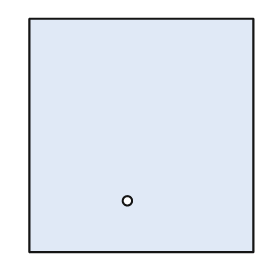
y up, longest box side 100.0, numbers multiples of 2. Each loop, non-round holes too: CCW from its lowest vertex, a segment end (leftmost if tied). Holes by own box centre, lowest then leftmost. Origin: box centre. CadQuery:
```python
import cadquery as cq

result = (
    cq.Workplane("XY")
    .moveTo(-48.0, -50.0)
    .lineTo(48.0, -50.0)
    .lineTo(48.0, 50.0)
    .lineTo(-48.0, 50.0)
    .close()
    .moveTo(-6.0, -28.0)
    .circle(2.0)
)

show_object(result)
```